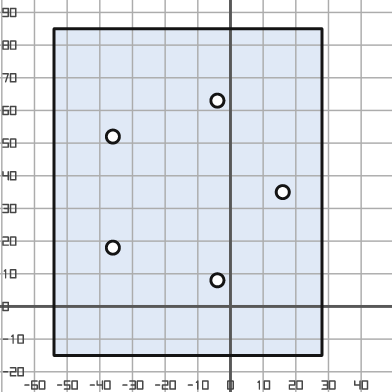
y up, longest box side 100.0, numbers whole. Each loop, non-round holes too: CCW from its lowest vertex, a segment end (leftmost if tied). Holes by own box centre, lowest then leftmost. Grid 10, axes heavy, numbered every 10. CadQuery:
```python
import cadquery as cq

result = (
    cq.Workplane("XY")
    .moveTo(-54.0, -15.0)
    .lineTo(28.0, -15.0)
    .lineTo(28.0, 85.0)
    .lineTo(-54.0, 85.0)
    .close()
    .moveTo(-4.0, 8.0)
    .circle(2.0)
    .moveTo(-36.0, 18.0)
    .circle(2.0)
    .moveTo(16.0, 35.0)
    .circle(2.0)
    .moveTo(-36.0, 52.0)
    .circle(2.0)
    .moveTo(-4.0, 63.0)
    .circle(2.0)
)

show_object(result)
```